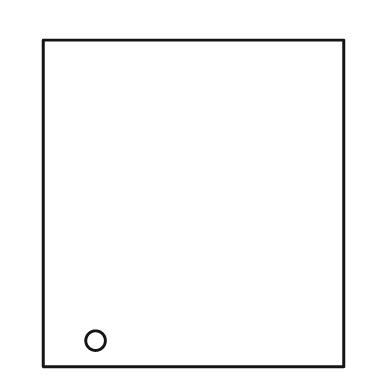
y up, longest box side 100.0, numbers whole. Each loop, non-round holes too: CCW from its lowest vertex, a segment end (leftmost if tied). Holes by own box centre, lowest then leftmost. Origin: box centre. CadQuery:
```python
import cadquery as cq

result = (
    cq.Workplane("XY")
    .moveTo(-46.0, -50.0)
    .lineTo(46.0, -50.0)
    .lineTo(46.0, 50.0)
    .lineTo(-46.0, 50.0)
    .close()
    .moveTo(-30.0, -42.0)
    .circle(3.0)
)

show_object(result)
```